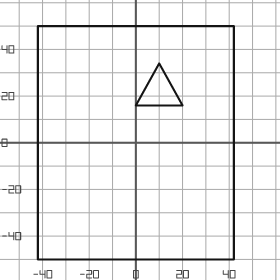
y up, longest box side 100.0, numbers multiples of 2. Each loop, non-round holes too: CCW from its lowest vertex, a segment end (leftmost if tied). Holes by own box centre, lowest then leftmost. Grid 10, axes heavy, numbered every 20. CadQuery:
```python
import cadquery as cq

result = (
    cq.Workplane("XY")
    .moveTo(-42.0, -50.0)
    .lineTo(42.0, -50.0)
    .lineTo(42.0, 50.0)
    .lineTo(-42.0, 50.0)
    .close()
    .moveTo(0.0, 16.0)
    .lineTo(20.0, 16.0)
    .lineTo(10.0, 34.0)
    .close()
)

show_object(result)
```